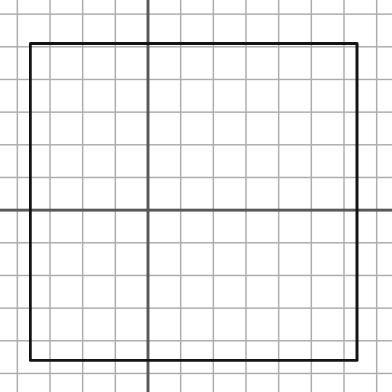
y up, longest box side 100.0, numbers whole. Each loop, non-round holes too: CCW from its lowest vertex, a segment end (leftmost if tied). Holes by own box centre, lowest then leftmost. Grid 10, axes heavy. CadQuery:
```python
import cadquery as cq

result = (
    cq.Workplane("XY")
    .moveTo(-36.0, -46.0)
    .lineTo(64.0, -46.0)
    .lineTo(64.0, 51.0)
    .lineTo(-36.0, 51.0)
    .close()
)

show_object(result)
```